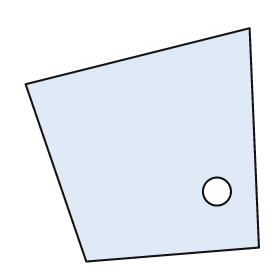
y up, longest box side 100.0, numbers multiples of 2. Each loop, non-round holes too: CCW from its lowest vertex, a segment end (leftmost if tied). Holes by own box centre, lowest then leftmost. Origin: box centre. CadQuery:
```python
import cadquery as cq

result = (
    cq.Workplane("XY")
    .moveTo(-24.0, -50.0)
    .lineTo(50.0, -44.0)
    .lineTo(46.0, 50.0)
    .lineTo(-50.0, 26.0)
    .close()
    .moveTo(32.0, -20.0)
    .circle(6.0)
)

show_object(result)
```